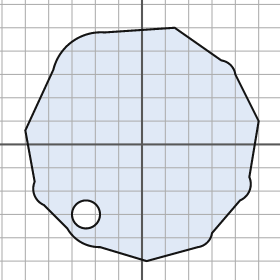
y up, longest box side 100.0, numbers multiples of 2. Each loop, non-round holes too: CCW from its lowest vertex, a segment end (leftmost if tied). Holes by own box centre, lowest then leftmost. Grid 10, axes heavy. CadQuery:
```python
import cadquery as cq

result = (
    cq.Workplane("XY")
    .moveTo(2.0, -50.0)
    .lineTo(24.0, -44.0)
    .threePointArc((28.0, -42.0), (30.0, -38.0))
    .lineTo(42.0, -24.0)
    .threePointArc((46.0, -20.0), (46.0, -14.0))
    .lineTo(50.0, 10.0)
    .lineTo(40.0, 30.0)
    .threePointArc((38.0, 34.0), (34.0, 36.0))
    .lineTo(14.0, 50.0)
    .lineTo(-16.0, 48.0)
    .threePointArc((-30.0, 44.0), (-38.0, 32.0))
    .lineTo(-50.0, 6.0)
    .lineTo(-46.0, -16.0)
    .threePointArc((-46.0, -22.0), (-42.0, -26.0))
    .lineTo(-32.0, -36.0)
    .threePointArc((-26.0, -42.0), (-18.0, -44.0))
    .close()
    .moveTo(-24.0, -30.0)
    .circle(6.0)
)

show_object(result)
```